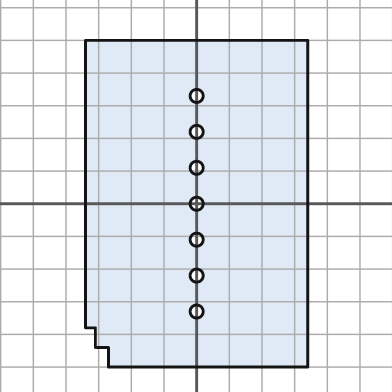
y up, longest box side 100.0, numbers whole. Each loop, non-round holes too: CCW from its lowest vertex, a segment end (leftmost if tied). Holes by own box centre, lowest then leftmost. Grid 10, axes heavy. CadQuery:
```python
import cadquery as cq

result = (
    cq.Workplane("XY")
    .moveTo(-27.0, -50.0)
    .lineTo(34.0, -50.0)
    .lineTo(34.0, 50.0)
    .lineTo(-34.0, 50.0)
    .lineTo(-34.0, -38.0)
    .lineTo(-31.0, -38.0)
    .lineTo(-31.0, -44.0)
    .lineTo(-27.0, -44.0)
    .close()
    .moveTo(0.0, -33.0)
    .circle(2.0)
    .moveTo(0.0, -22.0)
    .circle(2.0)
    .moveTo(0.0, -11.0)
    .circle(2.0)
    .moveTo(0.0, 0.0)
    .circle(2.0)
    .moveTo(0.0, 11.0)
    .circle(2.0)
    .moveTo(0.0, 22.0)
    .circle(2.0)
    .moveTo(0.0, 33.0)
    .circle(2.0)
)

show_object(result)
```